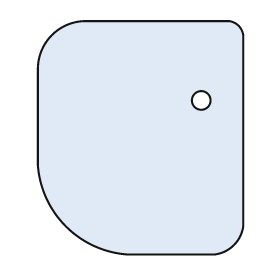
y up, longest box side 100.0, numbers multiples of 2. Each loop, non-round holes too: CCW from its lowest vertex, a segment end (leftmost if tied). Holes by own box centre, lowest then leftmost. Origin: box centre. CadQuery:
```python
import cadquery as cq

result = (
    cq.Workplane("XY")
    .moveTo(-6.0, -50.0)
    .lineTo(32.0, -50.0)
    .threePointArc((40.0, -46.0), (44.0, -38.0))
    .lineTo(44.0, 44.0)
    .threePointArc((42.0, 48.0), (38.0, 50.0))
    .lineTo(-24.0, 50.0)
    .threePointArc((-38.0, 44.0), (-44.0, 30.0))
    .lineTo(-44.0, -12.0)
    .threePointArc((-32.0, -38.0), (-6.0, -50.0))
    .close()
    .moveTo(26.0, 16.0)
    .circle(4.0)
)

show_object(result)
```